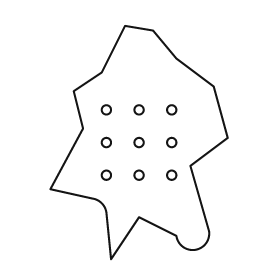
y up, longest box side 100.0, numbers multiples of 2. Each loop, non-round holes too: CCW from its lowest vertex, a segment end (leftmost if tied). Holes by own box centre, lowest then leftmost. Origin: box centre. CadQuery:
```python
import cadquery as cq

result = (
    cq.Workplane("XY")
    .moveTo(-12.0, -50.0)
    .lineTo(0.0, -32.0)
    .lineTo(16.0, -40.0)
    .threePointArc((24.0, -46.0), (30.0, -38.0))
    .lineTo(22.0, -10.0)
    .lineTo(38.0, 2.0)
    .lineTo(32.0, 24.0)
    .lineTo(16.0, 36.0)
    .lineTo(6.0, 48.0)
    .lineTo(-6.0, 50.0)
    .lineTo(-16.0, 30.0)
    .lineTo(-28.0, 22.0)
    .lineTo(-24.0, 6.0)
    .lineTo(-38.0, -20.0)
    .lineTo(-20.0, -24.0)
    .threePointArc((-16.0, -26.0), (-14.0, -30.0))
    .close()
    .moveTo(-14.0, -14.0)
    .circle(2.0)
    .moveTo(0.0, -14.0)
    .circle(2.0)
    .moveTo(14.0, -14.0)
    .circle(2.0)
    .moveTo(-14.0, 0.0)
    .circle(2.0)
    .moveTo(0.0, 0.0)
    .circle(2.0)
    .moveTo(14.0, 0.0)
    .circle(2.0)
    .moveTo(-14.0, 14.0)
    .circle(2.0)
    .moveTo(0.0, 14.0)
    .circle(2.0)
    .moveTo(14.0, 14.0)
    .circle(2.0)
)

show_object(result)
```